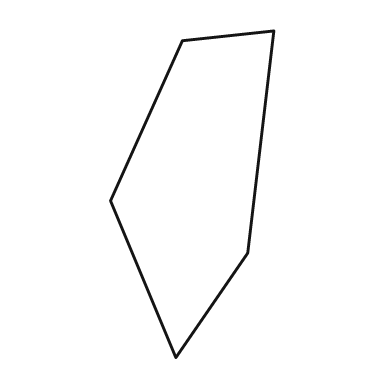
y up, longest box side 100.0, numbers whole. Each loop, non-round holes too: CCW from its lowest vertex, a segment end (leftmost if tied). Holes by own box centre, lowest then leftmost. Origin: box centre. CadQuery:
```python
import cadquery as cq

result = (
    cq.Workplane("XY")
    .moveTo(-5.0, -50.0)
    .lineTo(17.0, -18.0)
    .lineTo(25.0, 50.0)
    .lineTo(-3.0, 47.0)
    .lineTo(-25.0, -2.0)
    .close()
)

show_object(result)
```